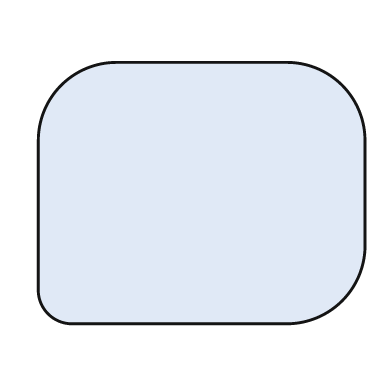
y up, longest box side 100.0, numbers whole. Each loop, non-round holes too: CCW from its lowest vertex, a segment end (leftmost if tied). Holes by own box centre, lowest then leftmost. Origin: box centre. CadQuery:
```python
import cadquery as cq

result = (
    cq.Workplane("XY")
    .moveTo(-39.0, -40.0)
    .lineTo(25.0, -40.0)
    .threePointArc((43.0, -33.0), (50.0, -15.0))
    .lineTo(50.0, 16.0)
    .threePointArc((43.0, 33.0), (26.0, 40.0))
    .lineTo(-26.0, 40.0)
    .threePointArc((-43.0, 33.0), (-50.0, 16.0))
    .lineTo(-50.0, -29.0)
    .threePointArc((-47.0, -37.0), (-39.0, -40.0))
    .close()
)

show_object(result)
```